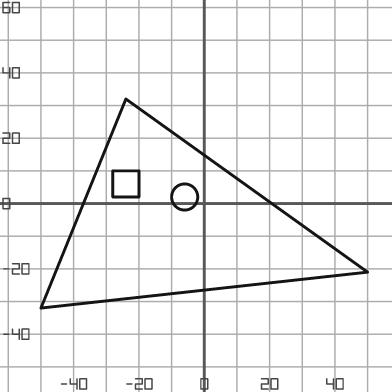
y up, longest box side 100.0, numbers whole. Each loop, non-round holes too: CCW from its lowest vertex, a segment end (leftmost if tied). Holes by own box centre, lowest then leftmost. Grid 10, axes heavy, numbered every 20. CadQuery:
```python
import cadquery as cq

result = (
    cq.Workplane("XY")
    .moveTo(-50.0, -32.0)
    .lineTo(50.0, -21.0)
    .lineTo(-24.0, 32.0)
    .close()
    .moveTo(-6.0, 2.0)
    .circle(4.0)
    .moveTo(-28.0, 2.0)
    .lineTo(-20.0, 2.0)
    .lineTo(-20.0, 10.0)
    .lineTo(-28.0, 10.0)
    .close()
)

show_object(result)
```